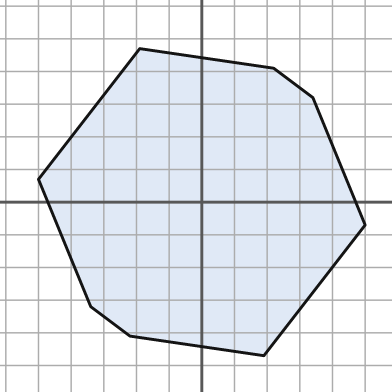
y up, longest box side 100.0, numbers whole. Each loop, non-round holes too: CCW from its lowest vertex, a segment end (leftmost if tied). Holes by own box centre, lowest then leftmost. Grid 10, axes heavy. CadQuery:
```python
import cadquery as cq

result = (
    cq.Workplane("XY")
    .moveTo(19.0, -47.0)
    .lineTo(50.0, -7.0)
    .lineTo(34.0, 32.0)
    .lineTo(22.0, 41.0)
    .lineTo(-19.0, 47.0)
    .lineTo(-50.0, 7.0)
    .lineTo(-34.0, -32.0)
    .lineTo(-22.0, -41.0)
    .close()
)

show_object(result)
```